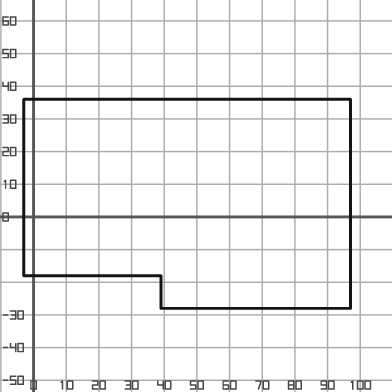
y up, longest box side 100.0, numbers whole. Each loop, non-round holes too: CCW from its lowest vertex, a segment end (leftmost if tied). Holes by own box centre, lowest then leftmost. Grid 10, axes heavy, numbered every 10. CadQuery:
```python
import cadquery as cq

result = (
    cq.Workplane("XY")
    .moveTo(39.0, -28.0)
    .lineTo(97.0, -28.0)
    .lineTo(97.0, 36.0)
    .lineTo(-3.0, 36.0)
    .lineTo(-3.0, -18.0)
    .lineTo(39.0, -18.0)
    .close()
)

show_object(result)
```